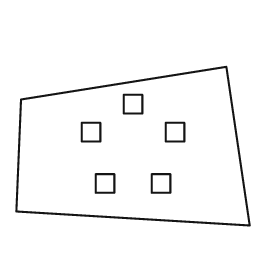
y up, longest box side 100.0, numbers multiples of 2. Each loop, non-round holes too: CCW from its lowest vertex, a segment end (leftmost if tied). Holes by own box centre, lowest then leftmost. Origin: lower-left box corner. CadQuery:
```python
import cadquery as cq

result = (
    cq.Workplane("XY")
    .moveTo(100.0, 0.0)
    .lineTo(90.0, 68.0)
    .lineTo(2.0, 54.0)
    .lineTo(0.0, 6.0)
    .close()
    .moveTo(34.0, 14.0)
    .lineTo(42.0, 14.0)
    .lineTo(42.0, 22.0)
    .lineTo(34.0, 22.0)
    .close()
    .moveTo(58.0, 14.0)
    .lineTo(66.0, 14.0)
    .lineTo(66.0, 22.0)
    .lineTo(58.0, 22.0)
    .close()
    .moveTo(28.0, 36.0)
    .lineTo(36.0, 36.0)
    .lineTo(36.0, 44.0)
    .lineTo(28.0, 44.0)
    .close()
    .moveTo(64.0, 36.0)
    .lineTo(72.0, 36.0)
    .lineTo(72.0, 44.0)
    .lineTo(64.0, 44.0)
    .close()
    .moveTo(46.0, 48.0)
    .lineTo(54.0, 48.0)
    .lineTo(54.0, 56.0)
    .lineTo(46.0, 56.0)
    .close()
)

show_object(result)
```